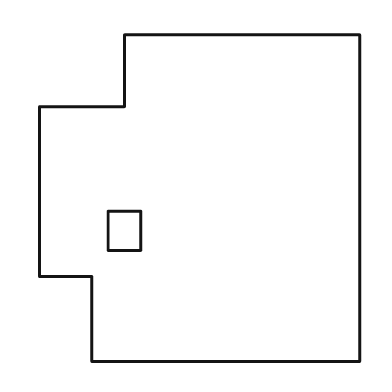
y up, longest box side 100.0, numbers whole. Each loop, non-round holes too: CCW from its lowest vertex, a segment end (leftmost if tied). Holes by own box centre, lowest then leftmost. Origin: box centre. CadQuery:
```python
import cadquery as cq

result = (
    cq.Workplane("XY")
    .moveTo(-33.0, -50.0)
    .lineTo(49.0, -50.0)
    .lineTo(49.0, 50.0)
    .lineTo(-23.0, 50.0)
    .lineTo(-23.0, 28.0)
    .lineTo(-49.0, 28.0)
    .lineTo(-49.0, -24.0)
    .lineTo(-33.0, -24.0)
    .close()
    .moveTo(-28.0, -16.0)
    .lineTo(-18.0, -16.0)
    .lineTo(-18.0, -4.0)
    .lineTo(-28.0, -4.0)
    .close()
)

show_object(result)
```